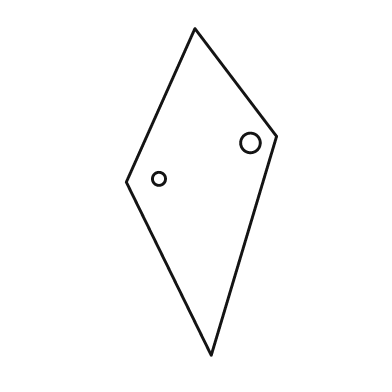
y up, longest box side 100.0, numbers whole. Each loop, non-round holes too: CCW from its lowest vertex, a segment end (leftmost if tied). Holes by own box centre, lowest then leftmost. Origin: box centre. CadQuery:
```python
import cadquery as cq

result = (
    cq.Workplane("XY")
    .moveTo(3.0, -50.0)
    .lineTo(23.0, 17.0)
    .lineTo(-2.0, 50.0)
    .lineTo(-23.0, 3.0)
    .close()
    .moveTo(-13.0, 4.0)
    .circle(2.0)
    .moveTo(15.0, 15.0)
    .circle(3.0)
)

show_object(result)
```